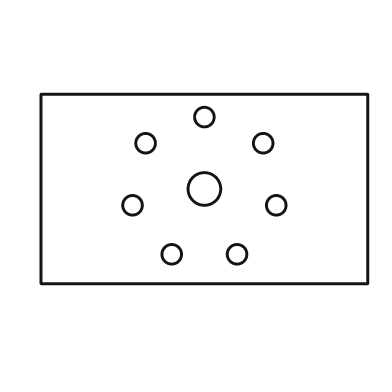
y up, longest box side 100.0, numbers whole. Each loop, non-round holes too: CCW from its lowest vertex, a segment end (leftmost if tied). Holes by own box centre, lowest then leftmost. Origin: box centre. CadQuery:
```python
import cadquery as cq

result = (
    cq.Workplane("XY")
    .moveTo(-50.0, -29.0)
    .lineTo(50.0, -29.0)
    .lineTo(50.0, 29.0)
    .lineTo(-50.0, 29.0)
    .close()
    .moveTo(-10.0, -20.0)
    .circle(3.0)
    .moveTo(10.0, -20.0)
    .circle(3.0)
    .moveTo(-22.0, -5.0)
    .circle(3.0)
    .moveTo(22.0, -5.0)
    .circle(3.0)
    .moveTo(0.0, 0.0)
    .circle(5.0)
    .moveTo(-18.0, 14.0)
    .circle(3.0)
    .moveTo(18.0, 14.0)
    .circle(3.0)
    .moveTo(0.0, 22.0)
    .circle(3.0)
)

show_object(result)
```